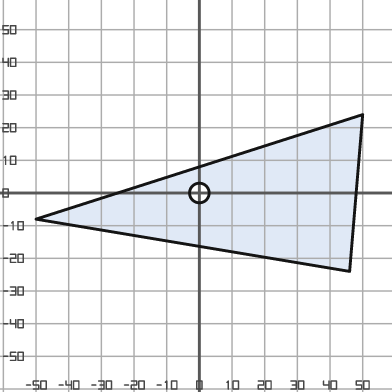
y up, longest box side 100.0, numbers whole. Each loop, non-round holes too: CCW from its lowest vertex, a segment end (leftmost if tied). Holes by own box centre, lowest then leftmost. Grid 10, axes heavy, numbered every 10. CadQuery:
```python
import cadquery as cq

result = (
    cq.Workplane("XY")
    .moveTo(46.0, -24.0)
    .lineTo(50.0, 24.0)
    .lineTo(-50.0, -8.0)
    .close()
    .moveTo(0.0, 0.0)
    .circle(3.0)
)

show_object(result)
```